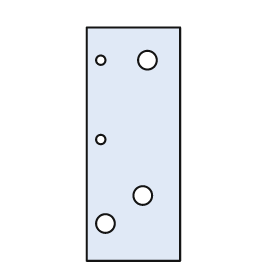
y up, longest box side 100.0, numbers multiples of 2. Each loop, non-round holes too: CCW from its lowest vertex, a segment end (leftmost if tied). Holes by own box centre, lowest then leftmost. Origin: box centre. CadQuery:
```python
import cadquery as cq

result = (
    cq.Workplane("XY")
    .moveTo(-20.0, -50.0)
    .lineTo(20.0, -50.0)
    .lineTo(20.0, 50.0)
    .lineTo(-20.0, 50.0)
    .close()
    .moveTo(-12.0, -34.0)
    .circle(4.0)
    .moveTo(4.0, -22.0)
    .circle(4.0)
    .moveTo(-14.0, 2.0)
    .circle(2.0)
    .moveTo(-14.0, 36.0)
    .circle(2.0)
    .moveTo(6.0, 36.0)
    .circle(4.0)
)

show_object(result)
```